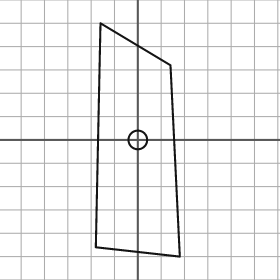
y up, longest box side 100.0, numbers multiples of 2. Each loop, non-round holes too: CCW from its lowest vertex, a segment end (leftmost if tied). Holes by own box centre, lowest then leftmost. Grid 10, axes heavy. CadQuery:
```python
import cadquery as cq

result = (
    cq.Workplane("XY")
    .moveTo(18.0, -50.0)
    .lineTo(14.0, 32.0)
    .lineTo(-16.0, 50.0)
    .lineTo(-18.0, -46.0)
    .close()
    .moveTo(0.0, 0.0)
    .circle(4.0)
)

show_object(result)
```